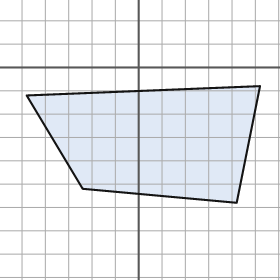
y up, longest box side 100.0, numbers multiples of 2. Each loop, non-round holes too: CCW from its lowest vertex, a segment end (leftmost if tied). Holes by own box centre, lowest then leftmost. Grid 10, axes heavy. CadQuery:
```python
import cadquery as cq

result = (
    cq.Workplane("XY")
    .moveTo(42.0, -58.0)
    .lineTo(52.0, -8.0)
    .lineTo(-48.0, -12.0)
    .lineTo(-24.0, -52.0)
    .close()
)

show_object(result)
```